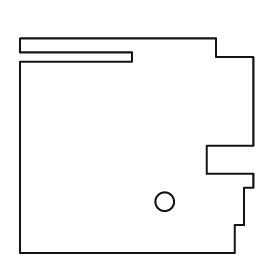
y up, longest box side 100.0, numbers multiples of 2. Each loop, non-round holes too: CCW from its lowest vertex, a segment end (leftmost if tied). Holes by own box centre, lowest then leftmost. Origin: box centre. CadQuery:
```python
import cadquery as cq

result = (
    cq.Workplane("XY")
    .moveTo(-50.0, -46.0)
    .lineTo(42.0, -46.0)
    .lineTo(42.0, -34.0)
    .lineTo(46.0, -34.0)
    .lineTo(46.0, -18.0)
    .lineTo(50.0, -18.0)
    .lineTo(50.0, -12.0)
    .lineTo(30.0, -12.0)
    .lineTo(30.0, 0.0)
    .lineTo(50.0, 0.0)
    .lineTo(50.0, 38.0)
    .lineTo(34.0, 38.0)
    .lineTo(34.0, 46.0)
    .lineTo(-50.0, 46.0)
    .lineTo(-50.0, 40.0)
    .lineTo(-2.0, 40.0)
    .lineTo(-2.0, 36.0)
    .lineTo(-50.0, 36.0)
    .close()
    .moveTo(12.0, -24.0)
    .circle(4.0)
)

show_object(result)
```